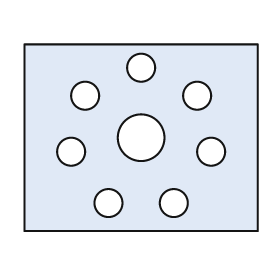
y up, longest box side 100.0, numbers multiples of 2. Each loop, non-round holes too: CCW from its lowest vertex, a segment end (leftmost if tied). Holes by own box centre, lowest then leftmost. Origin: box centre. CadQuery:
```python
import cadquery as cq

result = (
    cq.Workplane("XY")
    .moveTo(-50.0, -40.0)
    .lineTo(50.0, -40.0)
    .lineTo(50.0, 40.0)
    .lineTo(-50.0, 40.0)
    .close()
    .moveTo(-14.0, -28.0)
    .circle(6.0)
    .moveTo(14.0, -28.0)
    .circle(6.0)
    .moveTo(-30.0, -6.0)
    .circle(6.0)
    .moveTo(30.0, -6.0)
    .circle(6.0)
    .moveTo(0.0, 0.0)
    .circle(10.0)
    .moveTo(-24.0, 18.0)
    .circle(6.0)
    .moveTo(24.0, 18.0)
    .circle(6.0)
    .moveTo(0.0, 30.0)
    .circle(6.0)
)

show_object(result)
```